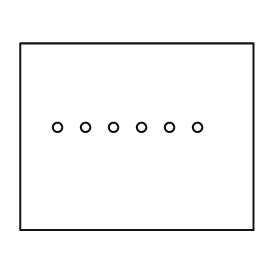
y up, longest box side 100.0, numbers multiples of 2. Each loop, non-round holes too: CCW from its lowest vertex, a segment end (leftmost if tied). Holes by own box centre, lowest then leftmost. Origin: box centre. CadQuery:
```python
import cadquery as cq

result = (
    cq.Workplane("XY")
    .moveTo(-50.0, -40.0)
    .lineTo(50.0, -40.0)
    .lineTo(50.0, 40.0)
    .lineTo(-50.0, 40.0)
    .close()
    .moveTo(-34.0, 4.0)
    .circle(2.0)
    .moveTo(-22.0, 4.0)
    .circle(2.0)
    .moveTo(-10.0, 4.0)
    .circle(2.0)
    .moveTo(2.0, 4.0)
    .circle(2.0)
    .moveTo(14.0, 4.0)
    .circle(2.0)
    .moveTo(26.0, 4.0)
    .circle(2.0)
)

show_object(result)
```